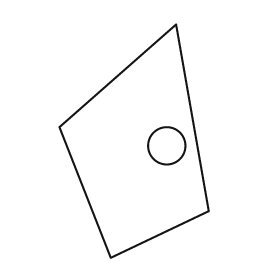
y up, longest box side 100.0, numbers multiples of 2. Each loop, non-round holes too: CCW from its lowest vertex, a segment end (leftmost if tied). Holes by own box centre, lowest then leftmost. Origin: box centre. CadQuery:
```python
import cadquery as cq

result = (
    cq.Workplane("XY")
    .moveTo(-10.0, -50.0)
    .lineTo(32.0, -30.0)
    .lineTo(18.0, 50.0)
    .lineTo(-32.0, 6.0)
    .close()
    .moveTo(14.0, -2.0)
    .circle(8.0)
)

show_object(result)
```